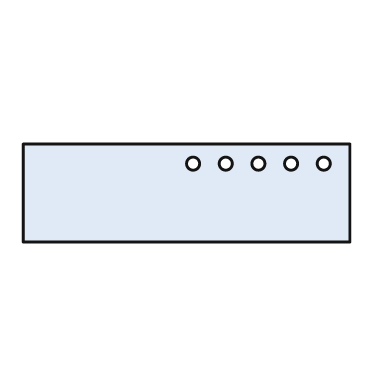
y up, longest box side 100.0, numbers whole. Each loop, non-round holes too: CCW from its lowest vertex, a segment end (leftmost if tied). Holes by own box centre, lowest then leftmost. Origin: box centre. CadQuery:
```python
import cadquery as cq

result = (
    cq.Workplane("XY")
    .moveTo(-50.0, -15.0)
    .lineTo(50.0, -15.0)
    .lineTo(50.0, 15.0)
    .lineTo(-50.0, 15.0)
    .close()
    .moveTo(2.0, 9.0)
    .circle(2.0)
    .moveTo(12.0, 9.0)
    .circle(2.0)
    .moveTo(22.0, 9.0)
    .circle(2.0)
    .moveTo(32.0, 9.0)
    .circle(2.0)
    .moveTo(42.0, 9.0)
    .circle(2.0)
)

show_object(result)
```